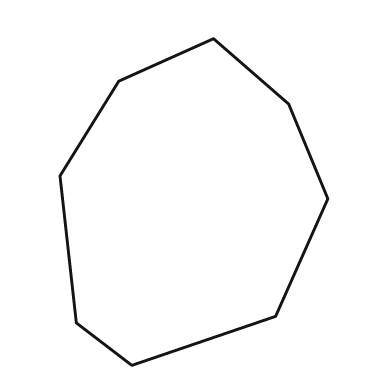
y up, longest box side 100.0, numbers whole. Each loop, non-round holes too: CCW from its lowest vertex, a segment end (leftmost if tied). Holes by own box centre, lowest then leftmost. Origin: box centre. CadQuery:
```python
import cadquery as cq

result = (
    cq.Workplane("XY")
    .moveTo(-19.0, -50.0)
    .lineTo(25.0, -35.0)
    .lineTo(41.0, 1.0)
    .lineTo(29.0, 30.0)
    .lineTo(6.0, 50.0)
    .lineTo(-23.0, 37.0)
    .lineTo(-41.0, 8.0)
    .lineTo(-36.0, -37.0)
    .close()
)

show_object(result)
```